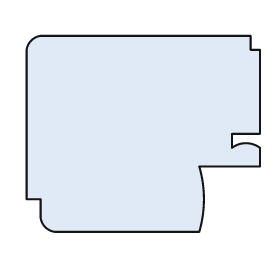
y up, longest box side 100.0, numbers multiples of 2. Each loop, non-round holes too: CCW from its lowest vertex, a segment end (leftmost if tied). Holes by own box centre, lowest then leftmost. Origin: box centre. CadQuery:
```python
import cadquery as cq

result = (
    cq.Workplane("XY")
    .moveTo(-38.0, -42.0)
    .lineTo(24.0, -42.0)
    .threePointArc((26.0, -28.0), (24.0, -14.0))
    .lineTo(50.0, -14.0)
    .lineTo(50.0, -6.0)
    .threePointArc((44.0, -4.0), (38.0, -6.0))
    .lineTo(38.0, 0.0)
    .lineTo(50.0, 0.0)
    .lineTo(50.0, 36.0)
    .lineTo(46.0, 36.0)
    .lineTo(46.0, 42.0)
    .lineTo(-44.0, 42.0)
    .threePointArc((-48.0, 40.0), (-50.0, 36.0))
    .lineTo(-50.0, -28.0)
    .lineTo(-44.0, -28.0)
    .lineTo(-44.0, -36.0)
    .threePointArc((-42.0, -40.0), (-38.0, -42.0))
    .close()
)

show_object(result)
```